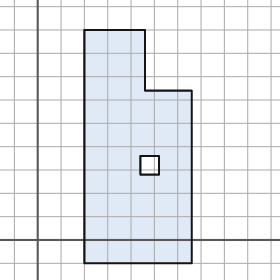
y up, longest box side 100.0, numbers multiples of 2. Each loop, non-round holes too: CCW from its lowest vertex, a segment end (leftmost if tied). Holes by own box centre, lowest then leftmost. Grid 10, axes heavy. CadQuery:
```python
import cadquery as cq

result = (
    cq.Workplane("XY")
    .moveTo(20.0, -10.0)
    .lineTo(66.0, -10.0)
    .lineTo(66.0, 64.0)
    .lineTo(46.0, 64.0)
    .lineTo(46.0, 90.0)
    .lineTo(20.0, 90.0)
    .close()
    .moveTo(44.0, 28.0)
    .lineTo(52.0, 28.0)
    .lineTo(52.0, 36.0)
    .lineTo(44.0, 36.0)
    .close()
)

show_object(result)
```